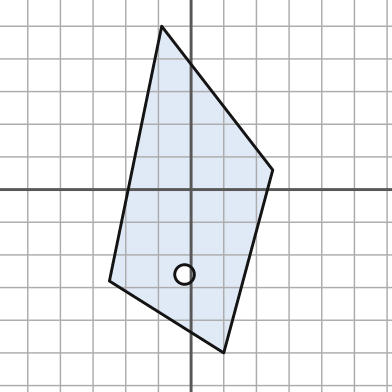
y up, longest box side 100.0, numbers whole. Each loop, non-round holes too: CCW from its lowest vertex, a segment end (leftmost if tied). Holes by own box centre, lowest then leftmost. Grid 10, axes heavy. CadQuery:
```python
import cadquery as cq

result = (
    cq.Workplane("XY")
    .moveTo(10.0, -50.0)
    .lineTo(25.0, 6.0)
    .lineTo(-9.0, 50.0)
    .lineTo(-25.0, -28.0)
    .close()
    .moveTo(-2.0, -26.0)
    .circle(3.0)
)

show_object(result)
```